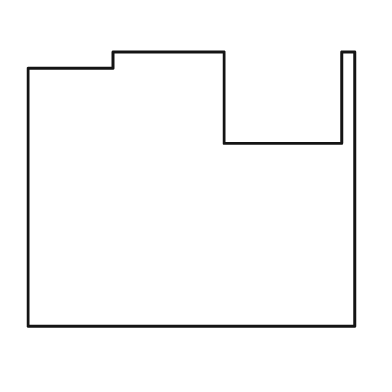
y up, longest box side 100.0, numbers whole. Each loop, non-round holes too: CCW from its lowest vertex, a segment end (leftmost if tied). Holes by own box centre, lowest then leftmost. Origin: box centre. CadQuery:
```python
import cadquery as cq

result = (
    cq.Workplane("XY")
    .moveTo(-50.0, -42.0)
    .lineTo(50.0, -42.0)
    .lineTo(50.0, 42.0)
    .lineTo(46.0, 42.0)
    .lineTo(46.0, 14.0)
    .lineTo(10.0, 14.0)
    .lineTo(10.0, 42.0)
    .lineTo(-24.0, 42.0)
    .lineTo(-24.0, 37.0)
    .lineTo(-50.0, 37.0)
    .close()
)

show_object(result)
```